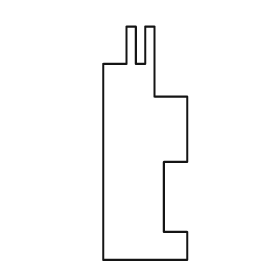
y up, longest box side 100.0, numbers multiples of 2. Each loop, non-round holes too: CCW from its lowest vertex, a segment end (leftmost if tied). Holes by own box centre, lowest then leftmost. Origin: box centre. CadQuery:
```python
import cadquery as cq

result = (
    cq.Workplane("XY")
    .moveTo(-18.0, -50.0)
    .lineTo(18.0, -50.0)
    .lineTo(18.0, -38.0)
    .lineTo(8.0, -38.0)
    .lineTo(8.0, -8.0)
    .lineTo(18.0, -8.0)
    .lineTo(18.0, 20.0)
    .lineTo(4.0, 20.0)
    .lineTo(4.0, 50.0)
    .lineTo(0.0, 50.0)
    .lineTo(0.0, 34.0)
    .lineTo(-4.0, 34.0)
    .lineTo(-4.0, 50.0)
    .lineTo(-8.0, 50.0)
    .lineTo(-8.0, 34.0)
    .lineTo(-18.0, 34.0)
    .close()
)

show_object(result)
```